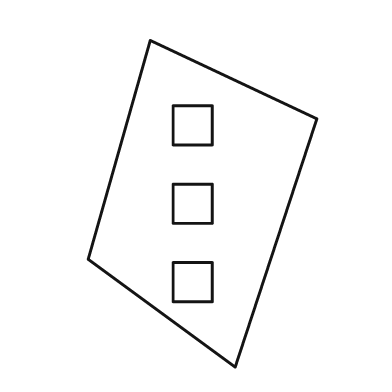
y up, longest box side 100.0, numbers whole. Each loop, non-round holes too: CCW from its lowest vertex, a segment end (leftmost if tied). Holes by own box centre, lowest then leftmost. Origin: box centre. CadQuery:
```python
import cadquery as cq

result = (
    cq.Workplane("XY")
    .moveTo(10.0, -50.0)
    .lineTo(35.0, 26.0)
    .lineTo(-16.0, 50.0)
    .lineTo(-35.0, -17.0)
    .close()
    .moveTo(-9.0, -30.0)
    .lineTo(3.0, -30.0)
    .lineTo(3.0, -18.0)
    .lineTo(-9.0, -18.0)
    .close()
    .moveTo(-9.0, -6.0)
    .lineTo(3.0, -6.0)
    .lineTo(3.0, 6.0)
    .lineTo(-9.0, 6.0)
    .close()
    .moveTo(-9.0, 18.0)
    .lineTo(3.0, 18.0)
    .lineTo(3.0, 30.0)
    .lineTo(-9.0, 30.0)
    .close()
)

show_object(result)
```